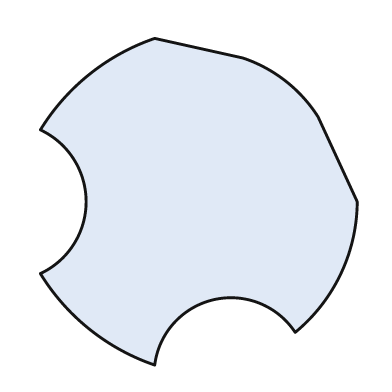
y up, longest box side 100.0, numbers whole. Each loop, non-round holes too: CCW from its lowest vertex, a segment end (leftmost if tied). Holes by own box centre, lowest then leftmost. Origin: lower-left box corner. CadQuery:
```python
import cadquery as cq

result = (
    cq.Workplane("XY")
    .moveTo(35.0, 0.0)
    .threePointArc((53.0, 20.0), (78.0, 10.0))
    .threePointArc((92.0, 28.0), (97.0, 50.0))
    .lineTo(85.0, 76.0)
    .threePointArc((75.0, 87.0), (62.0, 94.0))
    .lineTo(35.0, 100.0)
    .threePointArc((15.0, 89.0), (0.0, 72.0))
    .threePointArc((14.0, 50.0), (0.0, 28.0))
    .threePointArc((15.0, 11.0), (35.0, 0.0))
    .close()
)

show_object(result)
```